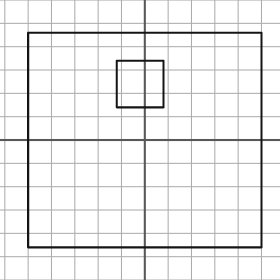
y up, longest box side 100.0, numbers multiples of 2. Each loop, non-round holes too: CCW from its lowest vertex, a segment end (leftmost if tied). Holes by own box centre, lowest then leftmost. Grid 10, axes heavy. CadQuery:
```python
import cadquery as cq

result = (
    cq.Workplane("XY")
    .moveTo(-50.0, -46.0)
    .lineTo(50.0, -46.0)
    .lineTo(50.0, 46.0)
    .lineTo(-50.0, 46.0)
    .close()
    .moveTo(-12.0, 14.0)
    .lineTo(8.0, 14.0)
    .lineTo(8.0, 34.0)
    .lineTo(-12.0, 34.0)
    .close()
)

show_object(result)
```